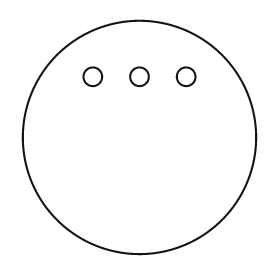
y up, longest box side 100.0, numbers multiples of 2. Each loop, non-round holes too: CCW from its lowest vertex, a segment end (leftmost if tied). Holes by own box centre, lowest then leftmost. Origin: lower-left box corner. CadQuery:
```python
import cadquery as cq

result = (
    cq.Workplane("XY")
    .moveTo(50.0, 50.0)
    .circle(50.0)
    .moveTo(30.0, 76.0)
    .circle(4.0)
    .moveTo(50.0, 76.0)
    .circle(4.0)
    .moveTo(70.0, 76.0)
    .circle(4.0)
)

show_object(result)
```